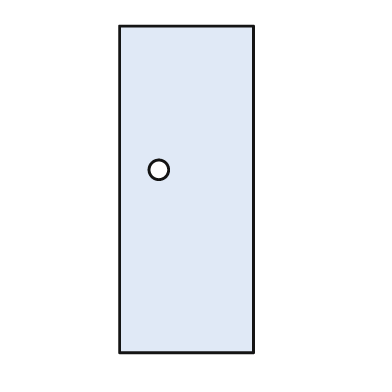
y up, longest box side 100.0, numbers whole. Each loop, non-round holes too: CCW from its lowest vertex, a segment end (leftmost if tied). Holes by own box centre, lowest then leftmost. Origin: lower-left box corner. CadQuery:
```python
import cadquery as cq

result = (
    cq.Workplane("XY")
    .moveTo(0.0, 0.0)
    .lineTo(41.0, 0.0)
    .lineTo(41.0, 100.0)
    .lineTo(0.0, 100.0)
    .close()
    .moveTo(12.0, 56.0)
    .circle(3.0)
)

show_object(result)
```